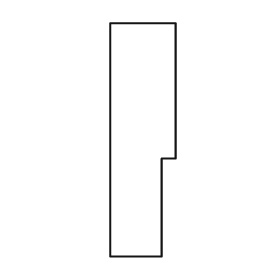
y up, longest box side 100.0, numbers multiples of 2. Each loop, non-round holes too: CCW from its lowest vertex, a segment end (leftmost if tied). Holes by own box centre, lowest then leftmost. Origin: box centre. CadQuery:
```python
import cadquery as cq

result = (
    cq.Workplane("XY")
    .moveTo(-14.0, -50.0)
    .lineTo(8.0, -50.0)
    .lineTo(8.0, -8.0)
    .lineTo(14.0, -8.0)
    .lineTo(14.0, 50.0)
    .lineTo(-14.0, 50.0)
    .close()
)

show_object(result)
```